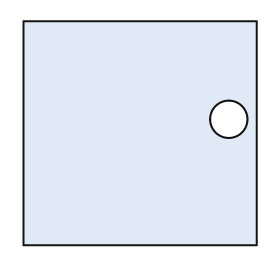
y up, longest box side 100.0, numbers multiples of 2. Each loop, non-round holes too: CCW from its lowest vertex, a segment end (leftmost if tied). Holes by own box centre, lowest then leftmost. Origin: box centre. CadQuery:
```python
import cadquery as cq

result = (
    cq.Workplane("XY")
    .moveTo(-50.0, -48.0)
    .lineTo(50.0, -48.0)
    .lineTo(50.0, 48.0)
    .lineTo(-50.0, 48.0)
    .close()
    .moveTo(38.0, 6.0)
    .circle(8.0)
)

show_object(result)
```